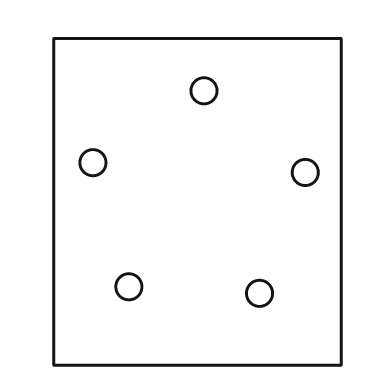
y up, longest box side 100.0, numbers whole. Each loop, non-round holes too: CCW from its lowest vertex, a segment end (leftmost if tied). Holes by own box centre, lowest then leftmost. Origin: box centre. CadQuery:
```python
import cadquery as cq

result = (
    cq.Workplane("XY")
    .moveTo(-44.0, -50.0)
    .lineTo(44.0, -50.0)
    .lineTo(44.0, 50.0)
    .lineTo(-44.0, 50.0)
    .close()
    .moveTo(19.0, -28.0)
    .circle(4.0)
    .moveTo(-21.0, -26.0)
    .circle(4.0)
    .moveTo(33.0, 9.0)
    .circle(4.0)
    .moveTo(-32.0, 12.0)
    .circle(4.0)
    .moveTo(2.0, 34.0)
    .circle(4.0)
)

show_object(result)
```